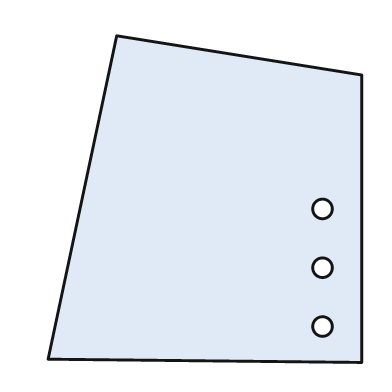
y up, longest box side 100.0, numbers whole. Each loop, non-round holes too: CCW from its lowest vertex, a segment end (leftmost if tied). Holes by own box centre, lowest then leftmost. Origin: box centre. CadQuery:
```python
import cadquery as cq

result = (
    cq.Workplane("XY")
    .moveTo(48.0, -50.0)
    .lineTo(48.0, 38.0)
    .lineTo(-27.0, 50.0)
    .lineTo(-48.0, -49.0)
    .close()
    .moveTo(36.0, -39.0)
    .circle(3.0)
    .moveTo(36.0, -21.0)
    .circle(3.0)
    .moveTo(36.0, -3.0)
    .circle(3.0)
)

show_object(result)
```